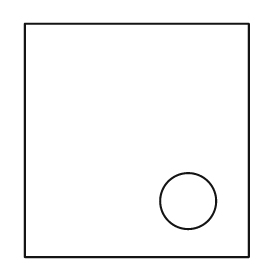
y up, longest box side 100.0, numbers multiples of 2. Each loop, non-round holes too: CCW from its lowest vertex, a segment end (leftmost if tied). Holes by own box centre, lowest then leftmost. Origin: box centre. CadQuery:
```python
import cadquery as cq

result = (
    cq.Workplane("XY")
    .moveTo(-48.0, -50.0)
    .lineTo(48.0, -50.0)
    .lineTo(48.0, 50.0)
    .lineTo(-48.0, 50.0)
    .close()
    .moveTo(22.0, -26.0)
    .circle(12.0)
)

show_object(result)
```